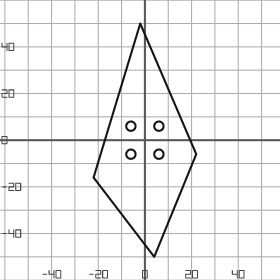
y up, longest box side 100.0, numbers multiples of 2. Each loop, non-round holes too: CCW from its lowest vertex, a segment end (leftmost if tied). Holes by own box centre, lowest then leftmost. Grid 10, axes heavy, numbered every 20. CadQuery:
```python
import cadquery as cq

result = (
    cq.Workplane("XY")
    .moveTo(4.0, -50.0)
    .lineTo(22.0, -6.0)
    .lineTo(-2.0, 50.0)
    .lineTo(-22.0, -16.0)
    .close()
    .moveTo(-6.0, -6.0)
    .circle(2.0)
    .moveTo(6.0, -6.0)
    .circle(2.0)
    .moveTo(-6.0, 6.0)
    .circle(2.0)
    .moveTo(6.0, 6.0)
    .circle(2.0)
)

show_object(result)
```